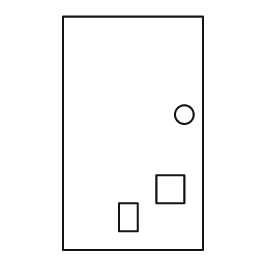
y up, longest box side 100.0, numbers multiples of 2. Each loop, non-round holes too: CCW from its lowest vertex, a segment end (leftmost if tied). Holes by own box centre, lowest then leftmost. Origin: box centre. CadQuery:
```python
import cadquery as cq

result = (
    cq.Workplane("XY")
    .moveTo(-30.0, -50.0)
    .lineTo(30.0, -50.0)
    .lineTo(30.0, 50.0)
    .lineTo(-30.0, 50.0)
    .close()
    .moveTo(-6.0, -42.0)
    .lineTo(2.0, -42.0)
    .lineTo(2.0, -30.0)
    .lineTo(-6.0, -30.0)
    .close()
    .moveTo(10.0, -30.0)
    .lineTo(22.0, -30.0)
    .lineTo(22.0, -18.0)
    .lineTo(10.0, -18.0)
    .close()
    .moveTo(22.0, 8.0)
    .circle(4.0)
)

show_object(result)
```